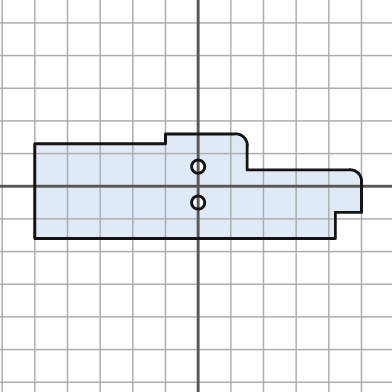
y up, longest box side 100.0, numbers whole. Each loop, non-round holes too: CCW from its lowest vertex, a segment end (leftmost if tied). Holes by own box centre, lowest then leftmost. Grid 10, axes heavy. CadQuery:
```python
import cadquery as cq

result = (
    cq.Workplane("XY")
    .moveTo(-50.0, -16.0)
    .lineTo(42.0, -16.0)
    .lineTo(42.0, -8.0)
    .lineTo(50.0, -8.0)
    .lineTo(50.0, 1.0)
    .threePointArc((49.0, 4.0), (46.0, 5.0))
    .lineTo(15.0, 5.0)
    .lineTo(15.0, 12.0)
    .threePointArc((14.0, 15.0), (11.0, 16.0))
    .lineTo(-10.0, 16.0)
    .lineTo(-10.0, 13.0)
    .lineTo(-50.0, 13.0)
    .close()
    .moveTo(0.0, -5.0)
    .circle(2.0)
    .moveTo(0.0, 6.0)
    .circle(2.0)
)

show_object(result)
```